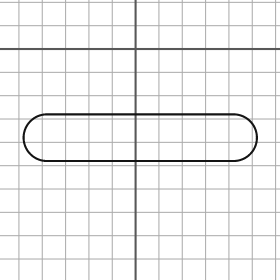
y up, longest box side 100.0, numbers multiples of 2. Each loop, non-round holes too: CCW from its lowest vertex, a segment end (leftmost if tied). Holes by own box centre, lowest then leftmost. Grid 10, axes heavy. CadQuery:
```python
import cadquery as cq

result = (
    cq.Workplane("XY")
    .moveTo(-38.0, -48.0)
    .lineTo(42.0, -48.0)
    .threePointArc((52.0, -38.0), (42.0, -28.0))
    .lineTo(-38.0, -28.0)
    .threePointArc((-48.0, -38.0), (-38.0, -48.0))
    .close()
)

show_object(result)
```